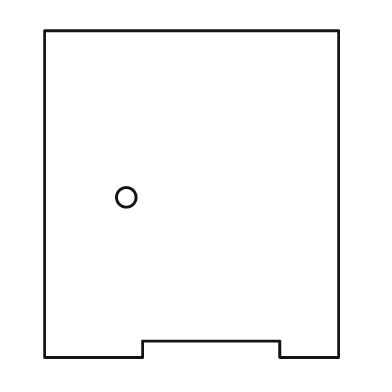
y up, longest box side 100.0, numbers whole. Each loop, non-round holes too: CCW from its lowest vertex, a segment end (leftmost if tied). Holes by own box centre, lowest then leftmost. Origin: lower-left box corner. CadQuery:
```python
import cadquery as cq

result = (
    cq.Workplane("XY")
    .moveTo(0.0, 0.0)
    .lineTo(30.0, 0.0)
    .lineTo(30.0, 5.0)
    .lineTo(72.0, 5.0)
    .lineTo(72.0, 0.0)
    .lineTo(90.0, 0.0)
    .lineTo(90.0, 100.0)
    .lineTo(0.0, 100.0)
    .close()
    .moveTo(25.0, 49.0)
    .circle(3.0)
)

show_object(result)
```